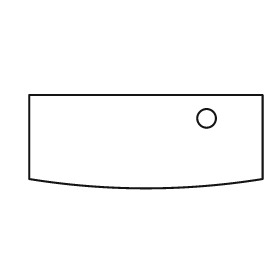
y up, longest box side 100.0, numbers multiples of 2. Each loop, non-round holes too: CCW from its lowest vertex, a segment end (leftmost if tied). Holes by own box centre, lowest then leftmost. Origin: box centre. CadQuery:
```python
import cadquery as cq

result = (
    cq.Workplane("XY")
    .moveTo(-50.0, -16.0)
    .threePointArc((0.0, -20.0), (50.0, -16.0))
    .lineTo(50.0, 20.0)
    .lineTo(-50.0, 20.0)
    .close()
    .moveTo(26.0, 10.0)
    .circle(4.0)
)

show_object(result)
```